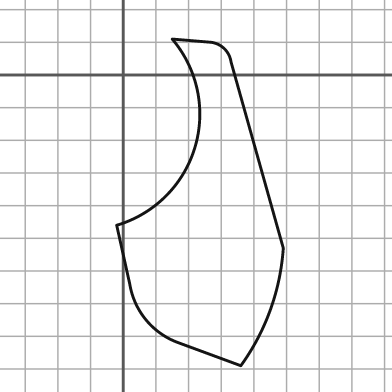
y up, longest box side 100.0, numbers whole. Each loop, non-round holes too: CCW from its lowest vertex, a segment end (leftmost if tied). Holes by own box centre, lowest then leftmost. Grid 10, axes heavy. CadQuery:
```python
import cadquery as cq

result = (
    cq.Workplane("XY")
    .moveTo(36.0, -89.0)
    .threePointArc((45.0, -72.0), (49.0, -53.0))
    .lineTo(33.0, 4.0)
    .threePointArc((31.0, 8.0), (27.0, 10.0))
    .lineTo(15.0, 11.0)
    .threePointArc((22.0, -22.0), (-2.0, -46.0))
    .lineTo(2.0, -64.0)
    .threePointArc((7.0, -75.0), (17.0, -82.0))
    .close()
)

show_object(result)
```